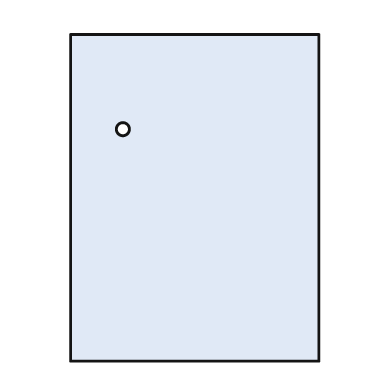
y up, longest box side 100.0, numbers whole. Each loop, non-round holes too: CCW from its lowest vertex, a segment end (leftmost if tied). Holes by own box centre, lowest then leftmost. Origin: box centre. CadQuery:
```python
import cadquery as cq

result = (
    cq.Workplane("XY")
    .moveTo(-38.0, -50.0)
    .lineTo(38.0, -50.0)
    .lineTo(38.0, 50.0)
    .lineTo(-38.0, 50.0)
    .close()
    .moveTo(-22.0, 21.0)
    .circle(2.0)
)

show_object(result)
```